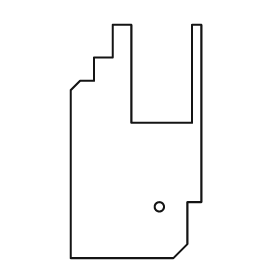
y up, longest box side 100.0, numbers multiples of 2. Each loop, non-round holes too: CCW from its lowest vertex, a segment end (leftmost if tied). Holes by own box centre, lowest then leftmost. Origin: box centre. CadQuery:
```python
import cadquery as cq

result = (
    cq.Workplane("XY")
    .moveTo(-28.0, -50.0)
    .lineTo(16.0, -50.0)
    .lineTo(22.0, -44.0)
    .lineTo(22.0, -26.0)
    .lineTo(28.0, -26.0)
    .lineTo(28.0, 50.0)
    .lineTo(24.0, 50.0)
    .lineTo(24.0, 8.0)
    .lineTo(-2.0, 8.0)
    .lineTo(-2.0, 50.0)
    .lineTo(-10.0, 50.0)
    .lineTo(-10.0, 36.0)
    .lineTo(-18.0, 36.0)
    .lineTo(-18.0, 26.0)
    .lineTo(-24.0, 26.0)
    .lineTo(-28.0, 22.0)
    .close()
    .moveTo(10.0, -28.0)
    .circle(2.0)
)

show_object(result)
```